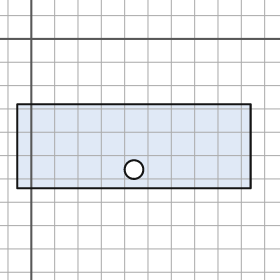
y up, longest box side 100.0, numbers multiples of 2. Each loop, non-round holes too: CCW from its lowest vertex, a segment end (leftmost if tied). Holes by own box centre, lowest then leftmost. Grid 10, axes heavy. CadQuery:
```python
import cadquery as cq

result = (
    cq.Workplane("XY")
    .moveTo(-6.0, -64.0)
    .lineTo(94.0, -64.0)
    .lineTo(94.0, -28.0)
    .lineTo(-6.0, -28.0)
    .close()
    .moveTo(44.0, -56.0)
    .circle(4.0)
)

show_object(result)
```